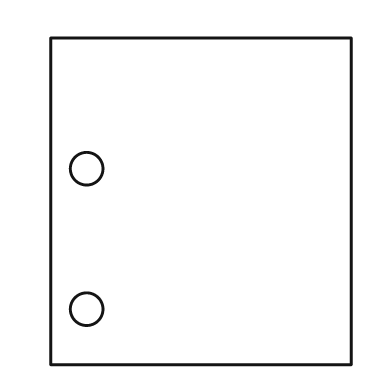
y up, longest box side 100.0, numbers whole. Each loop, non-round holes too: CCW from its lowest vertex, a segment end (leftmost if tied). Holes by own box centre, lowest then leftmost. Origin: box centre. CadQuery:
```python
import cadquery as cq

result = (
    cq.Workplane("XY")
    .moveTo(-46.0, -50.0)
    .lineTo(46.0, -50.0)
    .lineTo(46.0, 50.0)
    .lineTo(-46.0, 50.0)
    .close()
    .moveTo(-35.0, -33.0)
    .circle(5.0)
    .moveTo(-35.0, 10.0)
    .circle(5.0)
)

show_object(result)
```